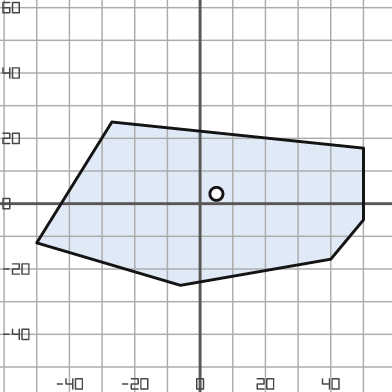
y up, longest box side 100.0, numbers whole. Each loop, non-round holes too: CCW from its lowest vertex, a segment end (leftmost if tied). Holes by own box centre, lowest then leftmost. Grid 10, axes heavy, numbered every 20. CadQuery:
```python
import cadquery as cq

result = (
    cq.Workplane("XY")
    .moveTo(-6.0, -25.0)
    .lineTo(40.0, -17.0)
    .lineTo(50.0, -5.0)
    .lineTo(50.0, 17.0)
    .lineTo(-27.0, 25.0)
    .lineTo(-50.0, -12.0)
    .close()
    .moveTo(5.0, 3.0)
    .circle(2.0)
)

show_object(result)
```